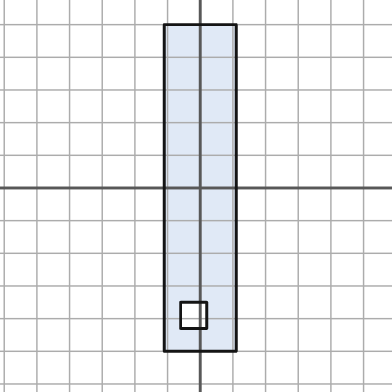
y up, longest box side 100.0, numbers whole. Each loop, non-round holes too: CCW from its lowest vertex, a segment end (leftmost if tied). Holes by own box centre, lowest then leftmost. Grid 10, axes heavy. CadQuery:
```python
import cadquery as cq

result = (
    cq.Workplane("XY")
    .moveTo(-11.0, -50.0)
    .lineTo(11.0, -50.0)
    .lineTo(11.0, 50.0)
    .lineTo(-11.0, 50.0)
    .close()
    .moveTo(-6.0, -43.0)
    .lineTo(2.0, -43.0)
    .lineTo(2.0, -35.0)
    .lineTo(-6.0, -35.0)
    .close()
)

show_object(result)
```